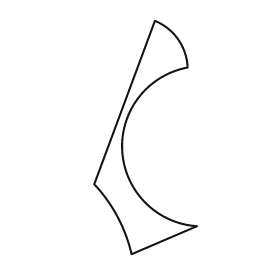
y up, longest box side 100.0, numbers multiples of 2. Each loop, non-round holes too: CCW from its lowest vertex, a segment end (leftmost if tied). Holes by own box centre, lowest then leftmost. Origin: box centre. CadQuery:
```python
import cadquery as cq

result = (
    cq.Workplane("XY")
    .moveTo(-6.0, -50.0)
    .lineTo(22.0, -38.0)
    .threePointArc((-10.0, -6.0), (18.0, 30.0))
    .threePointArc((14.0, 42.0), (4.0, 50.0))
    .lineTo(-22.0, -20.0)
    .threePointArc((-12.0, -34.0), (-6.0, -50.0))
    .close()
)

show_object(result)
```